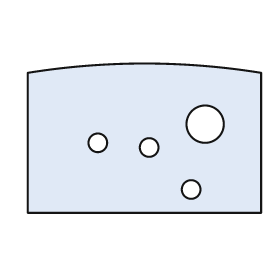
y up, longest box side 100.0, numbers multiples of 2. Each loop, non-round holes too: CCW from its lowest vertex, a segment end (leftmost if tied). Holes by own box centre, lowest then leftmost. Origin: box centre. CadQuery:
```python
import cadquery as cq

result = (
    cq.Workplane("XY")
    .moveTo(-50.0, -32.0)
    .lineTo(50.0, -32.0)
    .lineTo(50.0, 28.0)
    .threePointArc((0.0, 32.0), (-50.0, 28.0))
    .close()
    .moveTo(20.0, -22.0)
    .circle(4.0)
    .moveTo(2.0, -4.0)
    .circle(4.0)
    .moveTo(-20.0, -2.0)
    .circle(4.0)
    .moveTo(26.0, 6.0)
    .circle(8.0)
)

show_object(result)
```